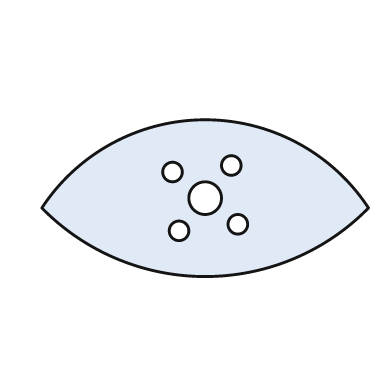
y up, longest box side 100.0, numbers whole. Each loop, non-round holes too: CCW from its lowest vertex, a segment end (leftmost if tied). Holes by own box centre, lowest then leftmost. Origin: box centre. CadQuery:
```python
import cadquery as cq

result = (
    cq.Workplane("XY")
    .moveTo(-50.0, -3.0)
    .threePointArc((0.0, -24.0), (50.0, -3.0))
    .threePointArc((0.0, 24.0), (-50.0, -3.0))
    .close()
    .moveTo(-8.0, -10.0)
    .circle(3.0)
    .moveTo(10.0, -8.0)
    .circle(3.0)
    .moveTo(0.0, 0.0)
    .circle(5.0)
    .moveTo(-10.0, 8.0)
    .circle(3.0)
    .moveTo(8.0, 10.0)
    .circle(3.0)
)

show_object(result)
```